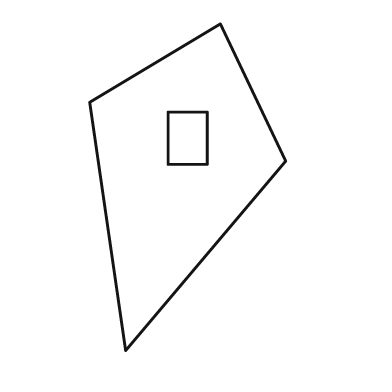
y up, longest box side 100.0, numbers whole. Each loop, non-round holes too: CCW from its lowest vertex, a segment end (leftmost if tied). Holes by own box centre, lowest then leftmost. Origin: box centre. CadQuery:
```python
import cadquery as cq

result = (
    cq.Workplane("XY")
    .moveTo(-19.0, -50.0)
    .lineTo(30.0, 8.0)
    .lineTo(10.0, 50.0)
    .lineTo(-30.0, 26.0)
    .close()
    .moveTo(-6.0, 7.0)
    .lineTo(6.0, 7.0)
    .lineTo(6.0, 23.0)
    .lineTo(-6.0, 23.0)
    .close()
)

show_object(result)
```